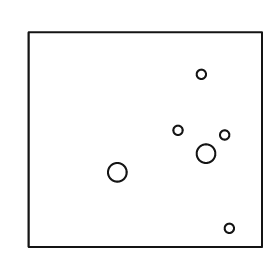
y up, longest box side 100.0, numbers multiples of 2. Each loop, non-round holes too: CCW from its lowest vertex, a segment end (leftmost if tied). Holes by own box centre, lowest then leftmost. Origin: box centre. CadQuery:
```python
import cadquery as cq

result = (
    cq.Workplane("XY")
    .moveTo(-50.0, -46.0)
    .lineTo(50.0, -46.0)
    .lineTo(50.0, 46.0)
    .lineTo(-50.0, 46.0)
    .close()
    .moveTo(36.0, -38.0)
    .circle(2.0)
    .moveTo(-12.0, -14.0)
    .circle(4.0)
    .moveTo(26.0, -6.0)
    .circle(4.0)
    .moveTo(34.0, 2.0)
    .circle(2.0)
    .moveTo(14.0, 4.0)
    .circle(2.0)
    .moveTo(24.0, 28.0)
    .circle(2.0)
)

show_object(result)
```